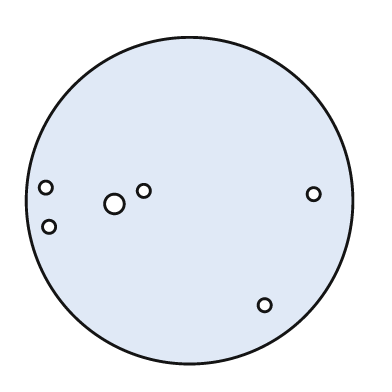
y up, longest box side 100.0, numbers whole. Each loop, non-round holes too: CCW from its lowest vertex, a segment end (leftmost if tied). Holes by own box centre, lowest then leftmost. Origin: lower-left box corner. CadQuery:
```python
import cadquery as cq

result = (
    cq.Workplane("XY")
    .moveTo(50.0, 50.0)
    .circle(50.0)
    .moveTo(73.0, 18.0)
    .circle(2.0)
    .moveTo(7.0, 42.0)
    .circle(2.0)
    .moveTo(27.0, 49.0)
    .circle(3.0)
    .moveTo(88.0, 52.0)
    .circle(2.0)
    .moveTo(36.0, 53.0)
    .circle(2.0)
    .moveTo(6.0, 54.0)
    .circle(2.0)
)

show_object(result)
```